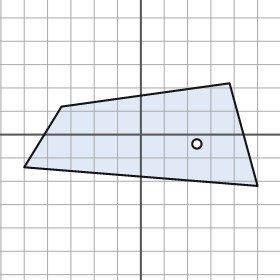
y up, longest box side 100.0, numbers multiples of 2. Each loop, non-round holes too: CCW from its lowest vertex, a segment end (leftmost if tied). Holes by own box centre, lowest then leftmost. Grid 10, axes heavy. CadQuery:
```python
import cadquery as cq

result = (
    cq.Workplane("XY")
    .moveTo(50.0, -22.0)
    .lineTo(38.0, 22.0)
    .lineTo(-34.0, 12.0)
    .lineTo(-50.0, -14.0)
    .close()
    .moveTo(24.0, -4.0)
    .circle(2.0)
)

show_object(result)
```